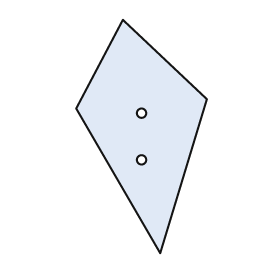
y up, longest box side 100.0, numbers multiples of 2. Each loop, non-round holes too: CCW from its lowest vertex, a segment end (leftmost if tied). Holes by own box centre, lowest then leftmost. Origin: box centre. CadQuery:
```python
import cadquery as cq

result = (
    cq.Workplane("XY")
    .moveTo(8.0, -50.0)
    .lineTo(28.0, 16.0)
    .lineTo(-8.0, 50.0)
    .lineTo(-28.0, 12.0)
    .close()
    .moveTo(0.0, -10.0)
    .circle(2.0)
    .moveTo(0.0, 10.0)
    .circle(2.0)
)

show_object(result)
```